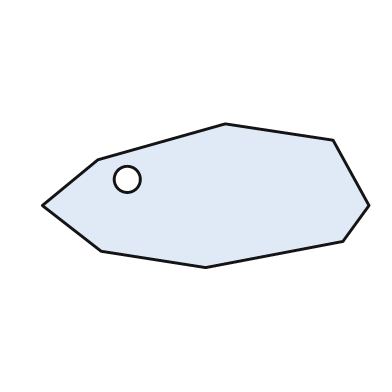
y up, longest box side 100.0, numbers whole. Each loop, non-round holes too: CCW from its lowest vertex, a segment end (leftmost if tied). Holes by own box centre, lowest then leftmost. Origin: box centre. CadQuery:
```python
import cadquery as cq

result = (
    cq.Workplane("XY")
    .moveTo(0.0, -22.0)
    .lineTo(42.0, -14.0)
    .lineTo(50.0, -3.0)
    .lineTo(39.0, 17.0)
    .lineTo(6.0, 22.0)
    .lineTo(-33.0, 11.0)
    .lineTo(-50.0, -3.0)
    .lineTo(-32.0, -17.0)
    .close()
    .moveTo(-24.0, 5.0)
    .circle(4.0)
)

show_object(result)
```